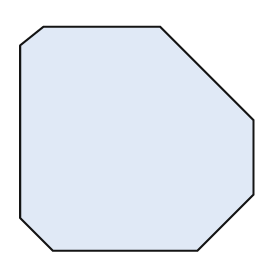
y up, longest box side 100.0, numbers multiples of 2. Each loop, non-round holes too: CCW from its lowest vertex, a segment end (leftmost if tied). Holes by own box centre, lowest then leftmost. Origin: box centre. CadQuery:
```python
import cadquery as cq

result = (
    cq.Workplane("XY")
    .moveTo(-36.0, -48.0)
    .lineTo(26.0, -48.0)
    .lineTo(50.0, -24.0)
    .lineTo(50.0, 8.0)
    .lineTo(10.0, 48.0)
    .lineTo(-40.0, 48.0)
    .lineTo(-50.0, 40.0)
    .lineTo(-50.0, -34.0)
    .close()
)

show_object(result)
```